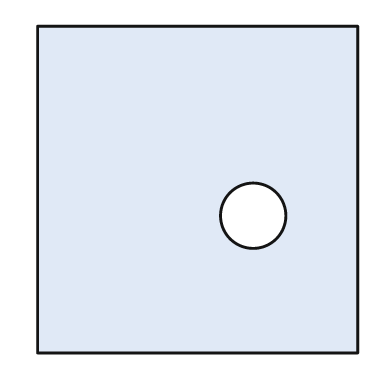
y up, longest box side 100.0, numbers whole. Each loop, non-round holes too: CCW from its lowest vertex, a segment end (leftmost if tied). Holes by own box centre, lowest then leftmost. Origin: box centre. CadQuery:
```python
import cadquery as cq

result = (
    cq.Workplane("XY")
    .moveTo(-49.0, -50.0)
    .lineTo(49.0, -50.0)
    .lineTo(49.0, 50.0)
    .lineTo(-49.0, 50.0)
    .close()
    .moveTo(17.0, -8.0)
    .circle(10.0)
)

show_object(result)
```